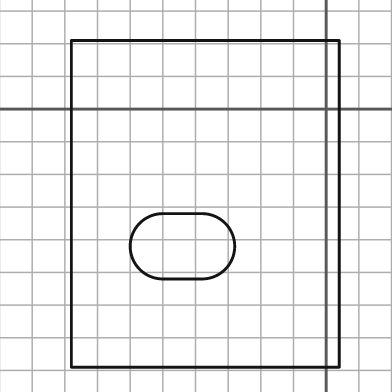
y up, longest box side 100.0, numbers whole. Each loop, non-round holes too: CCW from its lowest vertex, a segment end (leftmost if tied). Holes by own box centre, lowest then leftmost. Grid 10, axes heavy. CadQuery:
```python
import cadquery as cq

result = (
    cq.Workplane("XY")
    .moveTo(-78.0, -79.0)
    .lineTo(4.0, -79.0)
    .lineTo(4.0, 21.0)
    .lineTo(-78.0, 21.0)
    .close()
    .moveTo(-50.0, -52.0)
    .lineTo(-38.0, -52.0)
    .threePointArc((-28.0, -42.0), (-38.0, -32.0))
    .lineTo(-50.0, -32.0)
    .threePointArc((-60.0, -42.0), (-50.0, -52.0))
    .close()
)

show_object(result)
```